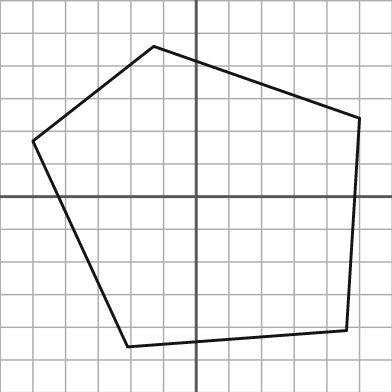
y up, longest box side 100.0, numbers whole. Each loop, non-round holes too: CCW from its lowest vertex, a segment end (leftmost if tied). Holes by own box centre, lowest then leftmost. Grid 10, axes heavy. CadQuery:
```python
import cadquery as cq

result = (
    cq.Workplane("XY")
    .moveTo(-21.0, -46.0)
    .lineTo(46.0, -41.0)
    .lineTo(50.0, 24.0)
    .lineTo(-13.0, 46.0)
    .lineTo(-50.0, 17.0)
    .close()
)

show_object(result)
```